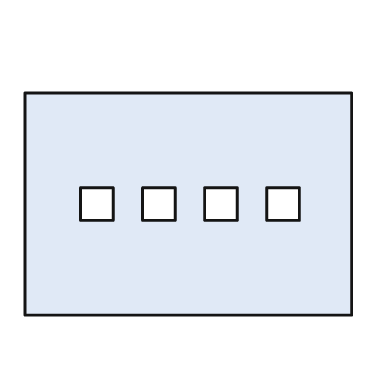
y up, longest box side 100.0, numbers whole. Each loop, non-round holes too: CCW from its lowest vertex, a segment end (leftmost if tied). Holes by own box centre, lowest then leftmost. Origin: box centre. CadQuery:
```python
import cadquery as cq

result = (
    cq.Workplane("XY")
    .moveTo(-50.0, -34.0)
    .lineTo(50.0, -34.0)
    .lineTo(50.0, 34.0)
    .lineTo(-50.0, 34.0)
    .close()
    .moveTo(-33.0, -5.0)
    .lineTo(-23.0, -5.0)
    .lineTo(-23.0, 5.0)
    .lineTo(-33.0, 5.0)
    .close()
    .moveTo(-14.0, -5.0)
    .lineTo(-4.0, -5.0)
    .lineTo(-4.0, 5.0)
    .lineTo(-14.0, 5.0)
    .close()
    .moveTo(5.0, -5.0)
    .lineTo(15.0, -5.0)
    .lineTo(15.0, 5.0)
    .lineTo(5.0, 5.0)
    .close()
    .moveTo(24.0, -5.0)
    .lineTo(34.0, -5.0)
    .lineTo(34.0, 5.0)
    .lineTo(24.0, 5.0)
    .close()
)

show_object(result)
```